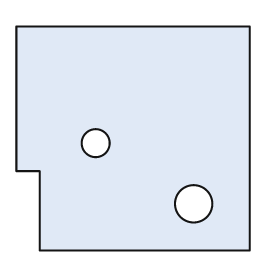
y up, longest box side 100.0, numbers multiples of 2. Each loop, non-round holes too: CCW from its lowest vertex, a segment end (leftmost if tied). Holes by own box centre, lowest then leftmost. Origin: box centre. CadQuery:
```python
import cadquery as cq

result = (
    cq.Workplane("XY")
    .moveTo(-40.0, -48.0)
    .lineTo(50.0, -48.0)
    .lineTo(50.0, 48.0)
    .lineTo(-50.0, 48.0)
    .lineTo(-50.0, -14.0)
    .lineTo(-40.0, -14.0)
    .close()
    .moveTo(26.0, -28.0)
    .circle(8.0)
    .moveTo(-16.0, -2.0)
    .circle(6.0)
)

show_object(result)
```